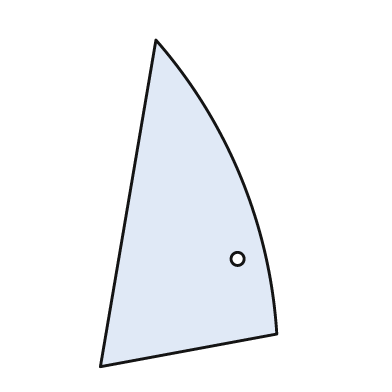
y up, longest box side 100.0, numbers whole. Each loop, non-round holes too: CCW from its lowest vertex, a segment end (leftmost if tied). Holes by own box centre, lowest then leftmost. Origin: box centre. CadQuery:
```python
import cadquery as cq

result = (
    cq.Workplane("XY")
    .moveTo(-27.0, -50.0)
    .lineTo(27.0, -40.0)
    .threePointArc((16.0, 8.0), (-10.0, 50.0))
    .close()
    .moveTo(15.0, -17.0)
    .circle(2.0)
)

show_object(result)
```